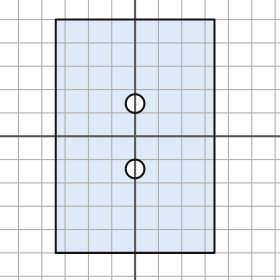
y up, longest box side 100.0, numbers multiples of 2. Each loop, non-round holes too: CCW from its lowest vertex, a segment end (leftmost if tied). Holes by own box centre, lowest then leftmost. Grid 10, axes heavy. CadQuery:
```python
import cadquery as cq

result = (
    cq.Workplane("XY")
    .moveTo(-34.0, -50.0)
    .lineTo(34.0, -50.0)
    .lineTo(34.0, 50.0)
    .lineTo(-34.0, 50.0)
    .close()
    .moveTo(0.0, -14.0)
    .circle(4.0)
    .moveTo(0.0, 14.0)
    .circle(4.0)
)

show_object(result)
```